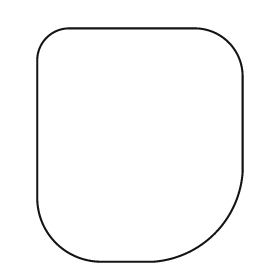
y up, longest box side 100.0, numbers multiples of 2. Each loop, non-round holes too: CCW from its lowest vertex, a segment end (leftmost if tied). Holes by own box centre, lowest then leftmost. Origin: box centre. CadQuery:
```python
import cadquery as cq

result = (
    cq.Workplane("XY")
    .moveTo(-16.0, -50.0)
    .lineTo(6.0, -50.0)
    .threePointArc((32.0, -38.0), (44.0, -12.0))
    .lineTo(44.0, 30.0)
    .threePointArc((38.0, 44.0), (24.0, 50.0))
    .lineTo(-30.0, 50.0)
    .threePointArc((-40.0, 46.0), (-44.0, 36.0))
    .lineTo(-44.0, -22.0)
    .threePointArc((-36.0, -42.0), (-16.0, -50.0))
    .close()
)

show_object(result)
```